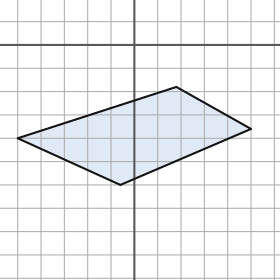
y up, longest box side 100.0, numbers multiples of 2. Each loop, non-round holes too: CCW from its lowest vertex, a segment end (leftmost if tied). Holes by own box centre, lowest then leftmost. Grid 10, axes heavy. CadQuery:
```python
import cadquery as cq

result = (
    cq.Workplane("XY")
    .moveTo(-6.0, -60.0)
    .lineTo(50.0, -36.0)
    .lineTo(18.0, -18.0)
    .lineTo(-50.0, -40.0)
    .close()
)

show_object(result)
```